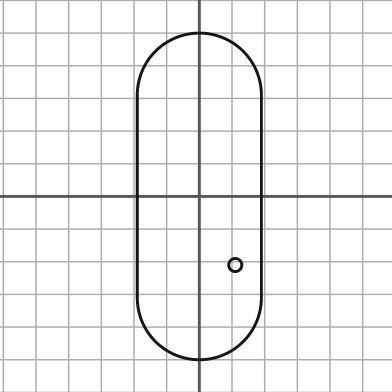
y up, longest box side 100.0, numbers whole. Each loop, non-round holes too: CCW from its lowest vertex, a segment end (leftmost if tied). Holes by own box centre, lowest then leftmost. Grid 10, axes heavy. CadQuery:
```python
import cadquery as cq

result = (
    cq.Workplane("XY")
    .moveTo(-19.0, -31.0)
    .threePointArc((0.0, -50.0), (19.0, -31.0))
    .lineTo(19.0, 31.0)
    .threePointArc((0.0, 50.0), (-19.0, 31.0))
    .close()
    .moveTo(11.0, -21.0)
    .circle(2.0)
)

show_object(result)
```